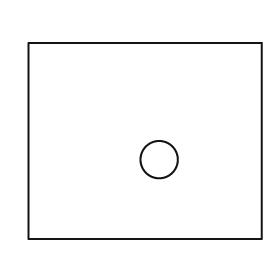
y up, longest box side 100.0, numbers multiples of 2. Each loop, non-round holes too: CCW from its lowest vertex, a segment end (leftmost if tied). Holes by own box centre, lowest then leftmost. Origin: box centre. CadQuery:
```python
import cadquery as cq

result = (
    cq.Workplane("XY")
    .moveTo(-50.0, -42.0)
    .lineTo(50.0, -42.0)
    .lineTo(50.0, 42.0)
    .lineTo(-50.0, 42.0)
    .close()
    .moveTo(6.0, -8.0)
    .circle(8.0)
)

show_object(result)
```